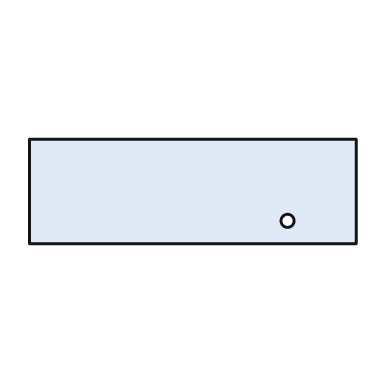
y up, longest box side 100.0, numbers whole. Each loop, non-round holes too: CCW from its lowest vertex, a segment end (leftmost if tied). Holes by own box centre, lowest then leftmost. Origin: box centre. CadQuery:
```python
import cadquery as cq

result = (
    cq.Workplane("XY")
    .moveTo(-50.0, -16.0)
    .lineTo(50.0, -16.0)
    .lineTo(50.0, 16.0)
    .lineTo(-50.0, 16.0)
    .close()
    .moveTo(29.0, -9.0)
    .circle(2.0)
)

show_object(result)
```